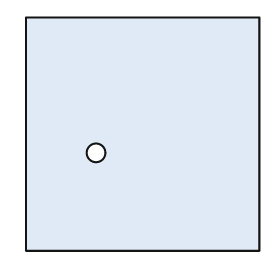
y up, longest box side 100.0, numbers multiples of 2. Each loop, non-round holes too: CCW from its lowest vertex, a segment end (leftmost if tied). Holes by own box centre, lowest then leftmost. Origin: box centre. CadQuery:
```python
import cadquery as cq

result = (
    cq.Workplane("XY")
    .moveTo(-50.0, -50.0)
    .lineTo(50.0, -50.0)
    .lineTo(50.0, 50.0)
    .lineTo(-50.0, 50.0)
    .close()
    .moveTo(-20.0, -8.0)
    .circle(4.0)
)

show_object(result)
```